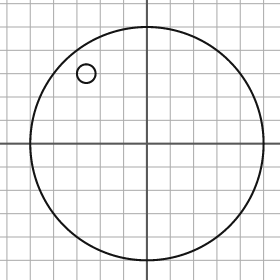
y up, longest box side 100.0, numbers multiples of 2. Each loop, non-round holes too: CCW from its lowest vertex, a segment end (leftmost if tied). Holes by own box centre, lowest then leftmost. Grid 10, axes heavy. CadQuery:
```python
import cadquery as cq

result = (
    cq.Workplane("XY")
    .moveTo(0.0, 0.0)
    .circle(50.0)
    .moveTo(-26.0, 30.0)
    .circle(4.0)
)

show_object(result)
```